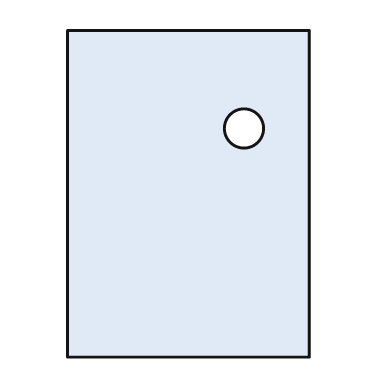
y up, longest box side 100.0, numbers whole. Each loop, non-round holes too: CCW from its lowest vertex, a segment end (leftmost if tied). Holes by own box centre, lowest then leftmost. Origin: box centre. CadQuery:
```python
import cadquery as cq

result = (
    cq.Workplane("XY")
    .moveTo(-37.0, -50.0)
    .lineTo(37.0, -50.0)
    .lineTo(37.0, 50.0)
    .lineTo(-37.0, 50.0)
    .close()
    .moveTo(17.0, 20.0)
    .circle(6.0)
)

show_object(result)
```